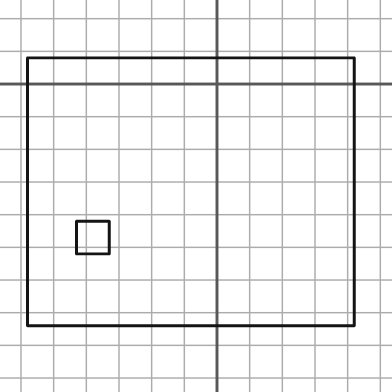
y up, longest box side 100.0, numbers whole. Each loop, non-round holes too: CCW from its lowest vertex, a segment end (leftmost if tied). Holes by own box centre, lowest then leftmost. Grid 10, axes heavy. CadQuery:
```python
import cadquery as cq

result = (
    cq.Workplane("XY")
    .moveTo(-58.0, -74.0)
    .lineTo(42.0, -74.0)
    .lineTo(42.0, 8.0)
    .lineTo(-58.0, 8.0)
    .close()
    .moveTo(-43.0, -52.0)
    .lineTo(-33.0, -52.0)
    .lineTo(-33.0, -42.0)
    .lineTo(-43.0, -42.0)
    .close()
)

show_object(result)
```